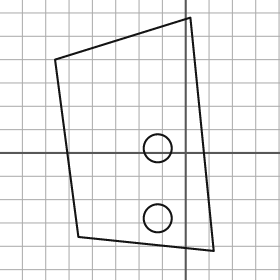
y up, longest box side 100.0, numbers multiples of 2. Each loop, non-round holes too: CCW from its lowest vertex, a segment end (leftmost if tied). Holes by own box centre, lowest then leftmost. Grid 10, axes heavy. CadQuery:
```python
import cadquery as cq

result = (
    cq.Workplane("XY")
    .moveTo(12.0, -42.0)
    .lineTo(2.0, 58.0)
    .lineTo(-56.0, 40.0)
    .lineTo(-46.0, -36.0)
    .close()
    .moveTo(-12.0, -28.0)
    .circle(6.0)
    .moveTo(-12.0, 2.0)
    .circle(6.0)
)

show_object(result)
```